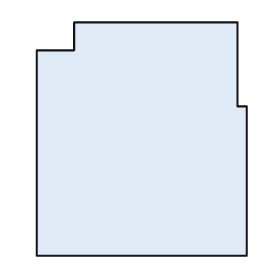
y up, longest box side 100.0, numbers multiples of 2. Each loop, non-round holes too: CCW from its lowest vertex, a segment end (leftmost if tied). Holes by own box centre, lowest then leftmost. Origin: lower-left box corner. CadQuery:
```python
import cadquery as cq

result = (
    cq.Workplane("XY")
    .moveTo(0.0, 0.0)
    .lineTo(90.0, 0.0)
    .lineTo(90.0, 64.0)
    .lineTo(86.0, 64.0)
    .lineTo(86.0, 100.0)
    .lineTo(16.0, 100.0)
    .lineTo(16.0, 88.0)
    .lineTo(0.0, 88.0)
    .close()
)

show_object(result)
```